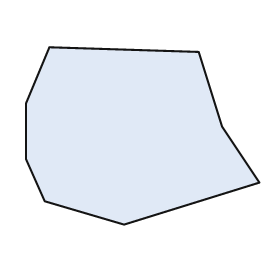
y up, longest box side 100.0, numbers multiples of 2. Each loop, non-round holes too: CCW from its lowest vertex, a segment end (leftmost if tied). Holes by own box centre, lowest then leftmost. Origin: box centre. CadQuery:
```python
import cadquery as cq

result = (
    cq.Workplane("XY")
    .moveTo(-8.0, -38.0)
    .lineTo(50.0, -20.0)
    .lineTo(34.0, 4.0)
    .lineTo(24.0, 36.0)
    .lineTo(-40.0, 38.0)
    .lineTo(-50.0, 14.0)
    .lineTo(-50.0, -10.0)
    .lineTo(-42.0, -28.0)
    .close()
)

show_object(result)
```